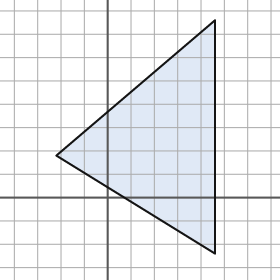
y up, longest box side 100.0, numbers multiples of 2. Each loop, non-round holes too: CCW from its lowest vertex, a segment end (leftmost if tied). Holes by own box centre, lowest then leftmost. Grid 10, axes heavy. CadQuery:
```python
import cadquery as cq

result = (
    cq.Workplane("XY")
    .moveTo(46.0, -24.0)
    .lineTo(46.0, 76.0)
    .lineTo(-22.0, 18.0)
    .close()
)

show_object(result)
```